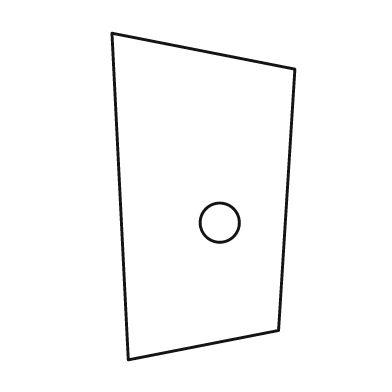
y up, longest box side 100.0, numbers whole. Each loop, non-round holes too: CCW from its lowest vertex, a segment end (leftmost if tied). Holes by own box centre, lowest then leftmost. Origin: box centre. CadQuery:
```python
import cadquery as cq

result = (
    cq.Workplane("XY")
    .moveTo(-23.0, -50.0)
    .lineTo(23.0, -41.0)
    .lineTo(28.0, 39.0)
    .lineTo(-28.0, 50.0)
    .close()
    .moveTo(5.0, -8.0)
    .circle(6.0)
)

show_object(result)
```